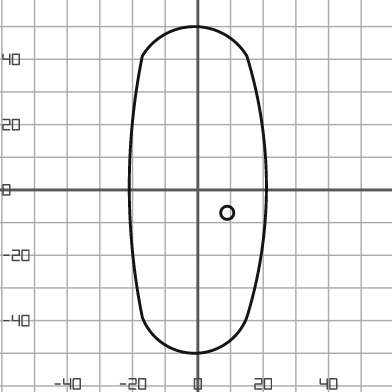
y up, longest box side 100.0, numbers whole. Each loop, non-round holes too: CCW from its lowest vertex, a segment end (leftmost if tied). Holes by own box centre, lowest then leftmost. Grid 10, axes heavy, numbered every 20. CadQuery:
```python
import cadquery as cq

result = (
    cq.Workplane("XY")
    .moveTo(-17.0, -39.0)
    .threePointArc((-1.0, -50.0), (15.0, -39.0))
    .threePointArc((21.0, 1.0), (15.0, 41.0))
    .threePointArc((-1.0, 50.0), (-17.0, 41.0))
    .threePointArc((-21.0, 1.0), (-17.0, -39.0))
    .close()
    .moveTo(9.0, -7.0)
    .circle(2.0)
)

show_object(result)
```